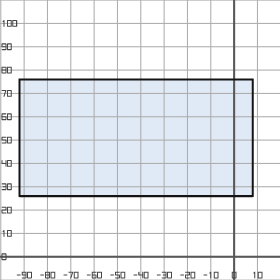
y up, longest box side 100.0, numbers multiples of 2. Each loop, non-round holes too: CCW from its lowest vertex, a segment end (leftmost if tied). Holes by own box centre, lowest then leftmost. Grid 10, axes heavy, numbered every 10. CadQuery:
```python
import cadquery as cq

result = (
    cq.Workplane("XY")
    .moveTo(-92.0, 26.0)
    .lineTo(8.0, 26.0)
    .lineTo(8.0, 76.0)
    .lineTo(-92.0, 76.0)
    .close()
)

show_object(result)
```